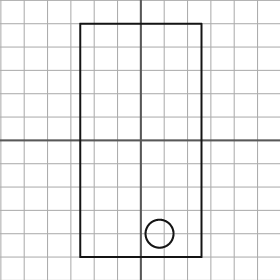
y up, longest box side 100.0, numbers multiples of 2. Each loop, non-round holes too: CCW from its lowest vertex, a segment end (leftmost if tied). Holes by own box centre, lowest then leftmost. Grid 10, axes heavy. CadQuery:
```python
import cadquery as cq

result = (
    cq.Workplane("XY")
    .moveTo(-26.0, -50.0)
    .lineTo(26.0, -50.0)
    .lineTo(26.0, 50.0)
    .lineTo(-26.0, 50.0)
    .close()
    .moveTo(8.0, -40.0)
    .circle(6.0)
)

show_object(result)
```